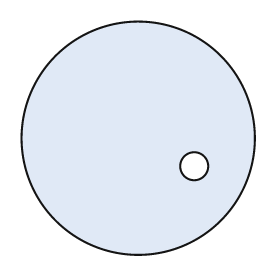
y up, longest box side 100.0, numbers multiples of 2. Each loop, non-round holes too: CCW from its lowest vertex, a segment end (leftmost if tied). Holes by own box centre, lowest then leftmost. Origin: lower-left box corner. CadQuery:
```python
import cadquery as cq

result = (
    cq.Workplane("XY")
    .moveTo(50.0, 50.0)
    .circle(50.0)
    .moveTo(74.0, 38.0)
    .circle(6.0)
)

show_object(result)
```